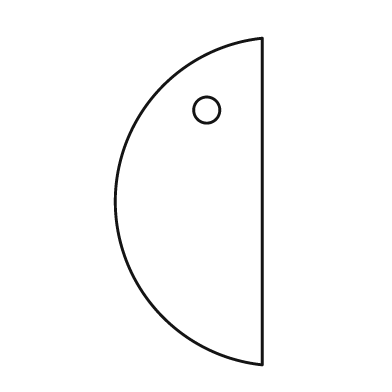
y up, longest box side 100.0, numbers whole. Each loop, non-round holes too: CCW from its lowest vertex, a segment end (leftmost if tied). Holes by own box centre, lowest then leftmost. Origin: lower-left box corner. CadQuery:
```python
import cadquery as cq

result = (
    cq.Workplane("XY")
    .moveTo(45.0, 0.0)
    .lineTo(45.0, 100.0)
    .threePointArc((0.0, 50.0), (45.0, 0.0))
    .close()
    .moveTo(28.0, 78.0)
    .circle(4.0)
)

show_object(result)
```